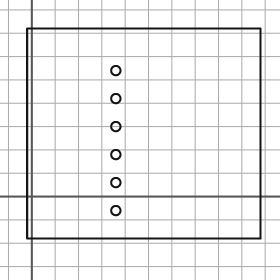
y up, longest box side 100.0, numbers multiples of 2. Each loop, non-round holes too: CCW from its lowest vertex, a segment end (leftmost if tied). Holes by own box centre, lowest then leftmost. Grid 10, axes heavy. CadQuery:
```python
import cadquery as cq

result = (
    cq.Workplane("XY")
    .moveTo(-2.0, -18.0)
    .lineTo(98.0, -18.0)
    .lineTo(98.0, 72.0)
    .lineTo(-2.0, 72.0)
    .close()
    .moveTo(36.0, -6.0)
    .circle(2.0)
    .moveTo(36.0, 6.0)
    .circle(2.0)
    .moveTo(36.0, 18.0)
    .circle(2.0)
    .moveTo(36.0, 30.0)
    .circle(2.0)
    .moveTo(36.0, 42.0)
    .circle(2.0)
    .moveTo(36.0, 54.0)
    .circle(2.0)
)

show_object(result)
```